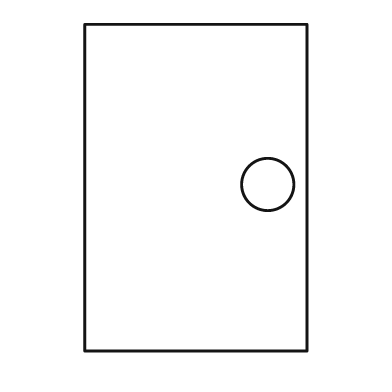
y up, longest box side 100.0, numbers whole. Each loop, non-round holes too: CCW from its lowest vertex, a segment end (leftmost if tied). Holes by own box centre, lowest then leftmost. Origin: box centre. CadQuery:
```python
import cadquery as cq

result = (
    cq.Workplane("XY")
    .moveTo(-34.0, -50.0)
    .lineTo(34.0, -50.0)
    .lineTo(34.0, 50.0)
    .lineTo(-34.0, 50.0)
    .close()
    .moveTo(22.0, 1.0)
    .circle(8.0)
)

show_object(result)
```